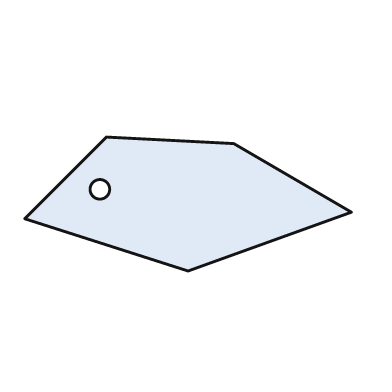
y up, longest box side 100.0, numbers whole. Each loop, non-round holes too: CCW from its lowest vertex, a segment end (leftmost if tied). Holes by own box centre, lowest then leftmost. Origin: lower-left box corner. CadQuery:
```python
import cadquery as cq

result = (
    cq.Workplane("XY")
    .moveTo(50.0, 0.0)
    .lineTo(100.0, 18.0)
    .lineTo(64.0, 39.0)
    .lineTo(25.0, 41.0)
    .lineTo(0.0, 16.0)
    .close()
    .moveTo(23.0, 25.0)
    .circle(3.0)
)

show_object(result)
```